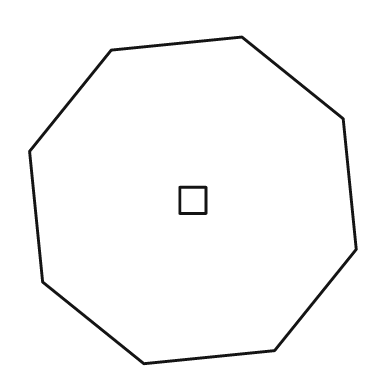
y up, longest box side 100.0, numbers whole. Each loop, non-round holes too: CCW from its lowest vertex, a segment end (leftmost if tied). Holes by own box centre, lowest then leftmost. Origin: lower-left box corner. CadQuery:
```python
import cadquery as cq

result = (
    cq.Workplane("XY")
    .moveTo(35.0, 0.0)
    .lineTo(75.0, 4.0)
    .lineTo(100.0, 35.0)
    .lineTo(96.0, 75.0)
    .lineTo(65.0, 100.0)
    .lineTo(25.0, 96.0)
    .lineTo(0.0, 65.0)
    .lineTo(4.0, 25.0)
    .close()
    .moveTo(46.0, 46.0)
    .lineTo(54.0, 46.0)
    .lineTo(54.0, 54.0)
    .lineTo(46.0, 54.0)
    .close()
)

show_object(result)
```